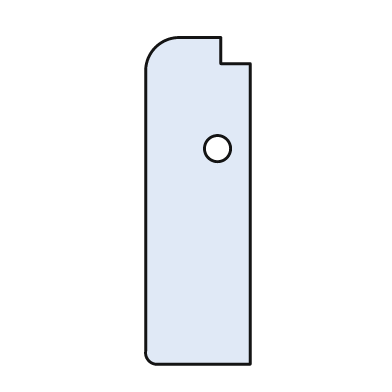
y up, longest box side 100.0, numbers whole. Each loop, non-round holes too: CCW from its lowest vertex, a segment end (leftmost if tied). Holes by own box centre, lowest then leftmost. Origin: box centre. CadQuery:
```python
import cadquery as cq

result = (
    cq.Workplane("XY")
    .moveTo(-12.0, -50.0)
    .lineTo(16.0, -50.0)
    .lineTo(16.0, 42.0)
    .lineTo(7.0, 42.0)
    .lineTo(7.0, 50.0)
    .lineTo(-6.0, 50.0)
    .threePointArc((-13.0, 47.0), (-16.0, 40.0))
    .lineTo(-16.0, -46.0)
    .threePointArc((-15.0, -49.0), (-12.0, -50.0))
    .close()
    .moveTo(6.0, 16.0)
    .circle(4.0)
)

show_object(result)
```